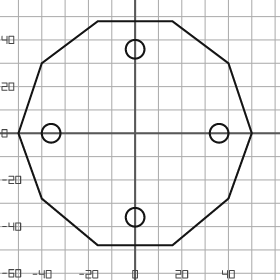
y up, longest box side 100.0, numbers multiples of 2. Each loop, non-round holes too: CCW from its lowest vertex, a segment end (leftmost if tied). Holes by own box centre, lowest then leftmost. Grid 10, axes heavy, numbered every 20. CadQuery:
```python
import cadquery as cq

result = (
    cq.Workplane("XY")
    .moveTo(-16.0, -48.0)
    .lineTo(16.0, -48.0)
    .lineTo(40.0, -28.0)
    .lineTo(50.0, 0.0)
    .lineTo(40.0, 30.0)
    .lineTo(16.0, 48.0)
    .lineTo(-16.0, 48.0)
    .lineTo(-40.0, 30.0)
    .lineTo(-50.0, 0.0)
    .lineTo(-40.0, -28.0)
    .close()
    .moveTo(0.0, -36.0)
    .circle(4.0)
    .moveTo(-36.0, 0.0)
    .circle(4.0)
    .moveTo(36.0, 0.0)
    .circle(4.0)
    .moveTo(0.0, 36.0)
    .circle(4.0)
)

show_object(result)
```